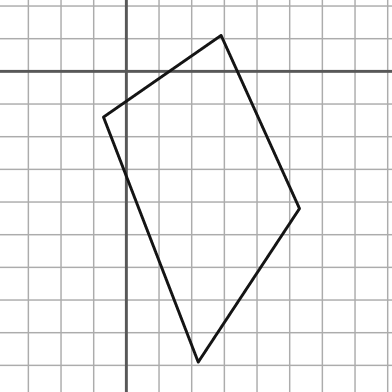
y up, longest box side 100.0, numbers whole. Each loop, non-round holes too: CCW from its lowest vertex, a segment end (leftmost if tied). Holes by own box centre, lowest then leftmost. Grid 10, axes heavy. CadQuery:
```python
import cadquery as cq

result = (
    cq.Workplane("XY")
    .moveTo(22.0, -89.0)
    .lineTo(53.0, -42.0)
    .lineTo(29.0, 11.0)
    .lineTo(-7.0, -14.0)
    .close()
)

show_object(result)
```